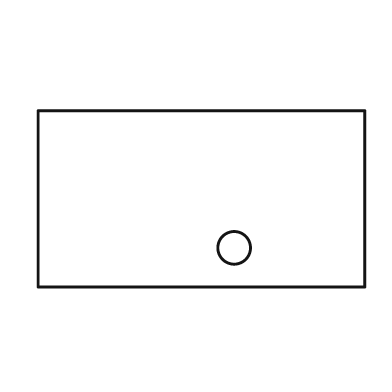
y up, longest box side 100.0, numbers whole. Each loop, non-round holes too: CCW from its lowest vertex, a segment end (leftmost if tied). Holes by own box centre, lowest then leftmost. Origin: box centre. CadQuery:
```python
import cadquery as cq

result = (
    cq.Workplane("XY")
    .moveTo(-50.0, -27.0)
    .lineTo(50.0, -27.0)
    .lineTo(50.0, 27.0)
    .lineTo(-50.0, 27.0)
    .close()
    .moveTo(10.0, -15.0)
    .circle(5.0)
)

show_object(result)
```